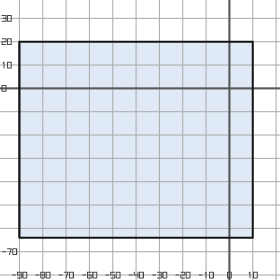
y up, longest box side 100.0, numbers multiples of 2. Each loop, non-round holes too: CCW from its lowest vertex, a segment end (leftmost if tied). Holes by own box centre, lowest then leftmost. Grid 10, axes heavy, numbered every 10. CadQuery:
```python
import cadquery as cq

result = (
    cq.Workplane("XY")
    .moveTo(-90.0, -64.0)
    .lineTo(10.0, -64.0)
    .lineTo(10.0, 20.0)
    .lineTo(-90.0, 20.0)
    .close()
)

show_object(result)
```